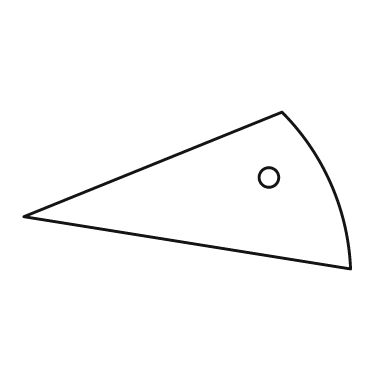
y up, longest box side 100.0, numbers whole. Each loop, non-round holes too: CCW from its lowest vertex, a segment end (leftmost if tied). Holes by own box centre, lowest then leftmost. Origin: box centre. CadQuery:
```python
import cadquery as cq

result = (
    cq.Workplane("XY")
    .moveTo(50.0, -24.0)
    .threePointArc((44.0, 2.0), (29.0, 24.0))
    .lineTo(-50.0, -8.0)
    .close()
    .moveTo(25.0, 4.0)
    .circle(3.0)
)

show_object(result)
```